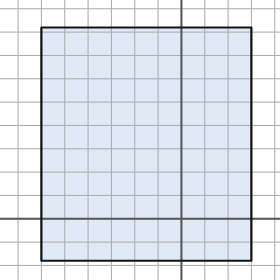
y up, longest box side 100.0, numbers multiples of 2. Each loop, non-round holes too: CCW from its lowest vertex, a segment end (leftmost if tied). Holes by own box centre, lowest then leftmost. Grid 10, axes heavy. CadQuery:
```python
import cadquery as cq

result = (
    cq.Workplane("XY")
    .moveTo(-60.0, -18.0)
    .lineTo(30.0, -18.0)
    .lineTo(30.0, 82.0)
    .lineTo(-60.0, 82.0)
    .close()
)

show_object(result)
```